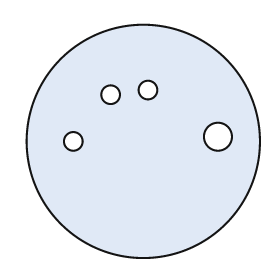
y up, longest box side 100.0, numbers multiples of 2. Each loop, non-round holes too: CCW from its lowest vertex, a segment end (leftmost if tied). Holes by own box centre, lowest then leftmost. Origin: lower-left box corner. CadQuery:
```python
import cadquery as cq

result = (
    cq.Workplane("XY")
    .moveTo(50.0, 50.0)
    .circle(50.0)
    .moveTo(20.0, 50.0)
    .circle(4.0)
    .moveTo(82.0, 52.0)
    .circle(6.0)
    .moveTo(36.0, 70.0)
    .circle(4.0)
    .moveTo(52.0, 72.0)
    .circle(4.0)
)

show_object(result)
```